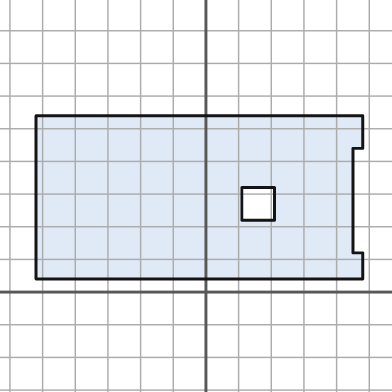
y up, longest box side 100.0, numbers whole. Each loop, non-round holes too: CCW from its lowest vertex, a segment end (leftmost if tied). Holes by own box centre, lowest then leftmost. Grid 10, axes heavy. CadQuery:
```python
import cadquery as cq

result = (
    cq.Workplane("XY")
    .moveTo(-52.0, 4.0)
    .lineTo(48.0, 4.0)
    .lineTo(48.0, 12.0)
    .lineTo(45.0, 12.0)
    .lineTo(45.0, 44.0)
    .lineTo(48.0, 44.0)
    .lineTo(48.0, 54.0)
    .lineTo(-52.0, 54.0)
    .close()
    .moveTo(11.0, 22.0)
    .lineTo(21.0, 22.0)
    .lineTo(21.0, 32.0)
    .lineTo(11.0, 32.0)
    .close()
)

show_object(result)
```